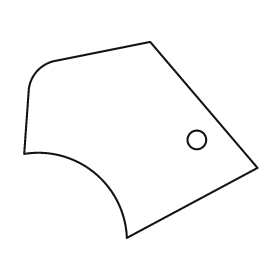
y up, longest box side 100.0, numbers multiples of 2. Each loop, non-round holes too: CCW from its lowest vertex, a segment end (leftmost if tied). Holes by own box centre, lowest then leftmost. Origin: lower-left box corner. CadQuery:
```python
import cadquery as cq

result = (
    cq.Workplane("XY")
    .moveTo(44.0, 0.0)
    .lineTo(100.0, 30.0)
    .lineTo(54.0, 84.0)
    .lineTo(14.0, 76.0)
    .threePointArc((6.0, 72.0), (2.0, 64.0))
    .lineTo(0.0, 36.0)
    .threePointArc((30.0, 28.0), (44.0, 0.0))
    .close()
    .moveTo(74.0, 42.0)
    .circle(4.0)
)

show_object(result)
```